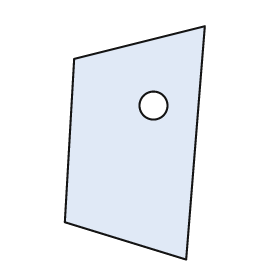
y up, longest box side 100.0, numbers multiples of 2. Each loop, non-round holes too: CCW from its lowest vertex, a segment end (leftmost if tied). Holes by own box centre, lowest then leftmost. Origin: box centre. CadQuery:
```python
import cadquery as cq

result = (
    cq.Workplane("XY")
    .moveTo(22.0, -50.0)
    .lineTo(30.0, 50.0)
    .lineTo(-26.0, 36.0)
    .lineTo(-30.0, -34.0)
    .close()
    .moveTo(8.0, 16.0)
    .circle(6.0)
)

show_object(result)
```